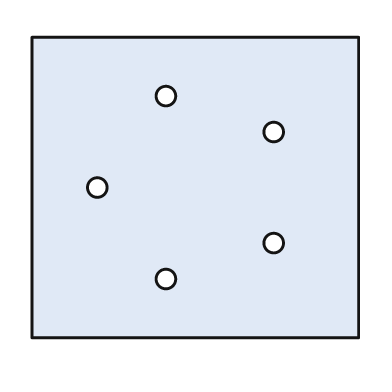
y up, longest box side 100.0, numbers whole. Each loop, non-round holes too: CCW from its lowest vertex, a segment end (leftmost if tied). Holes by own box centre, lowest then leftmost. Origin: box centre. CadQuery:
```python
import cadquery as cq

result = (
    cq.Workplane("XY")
    .moveTo(-50.0, -46.0)
    .lineTo(50.0, -46.0)
    .lineTo(50.0, 46.0)
    .lineTo(-50.0, 46.0)
    .close()
    .moveTo(-9.0, -28.0)
    .circle(3.0)
    .moveTo(24.0, -17.0)
    .circle(3.0)
    .moveTo(-30.0, 0.0)
    .circle(3.0)
    .moveTo(24.0, 17.0)
    .circle(3.0)
    .moveTo(-9.0, 28.0)
    .circle(3.0)
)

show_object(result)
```